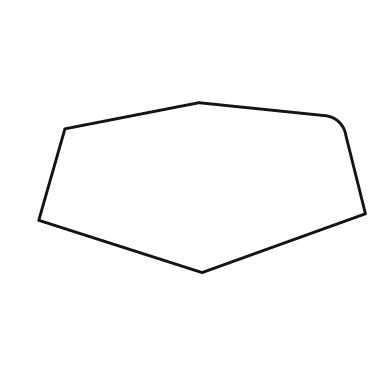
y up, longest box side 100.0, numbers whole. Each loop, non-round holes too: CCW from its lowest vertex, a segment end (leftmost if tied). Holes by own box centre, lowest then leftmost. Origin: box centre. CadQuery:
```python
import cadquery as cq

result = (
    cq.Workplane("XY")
    .moveTo(0.0, -26.0)
    .lineTo(50.0, -8.0)
    .lineTo(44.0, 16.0)
    .threePointArc((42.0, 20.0), (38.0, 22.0))
    .lineTo(-1.0, 26.0)
    .lineTo(-42.0, 18.0)
    .lineTo(-50.0, -10.0)
    .close()
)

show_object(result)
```